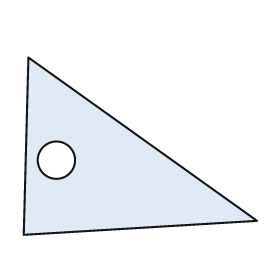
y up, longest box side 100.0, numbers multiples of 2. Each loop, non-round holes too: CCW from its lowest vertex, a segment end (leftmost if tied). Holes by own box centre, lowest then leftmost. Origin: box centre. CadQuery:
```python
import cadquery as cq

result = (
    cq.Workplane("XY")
    .moveTo(-50.0, -38.0)
    .lineTo(50.0, -32.0)
    .lineTo(-48.0, 38.0)
    .close()
    .moveTo(-36.0, -6.0)
    .circle(8.0)
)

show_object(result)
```